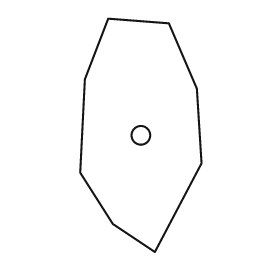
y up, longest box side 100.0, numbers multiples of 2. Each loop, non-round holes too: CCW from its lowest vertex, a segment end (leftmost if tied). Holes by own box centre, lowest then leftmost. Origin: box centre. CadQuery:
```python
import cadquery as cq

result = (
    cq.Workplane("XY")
    .moveTo(6.0, -50.0)
    .lineTo(26.0, -12.0)
    .lineTo(24.0, 20.0)
    .lineTo(12.0, 48.0)
    .lineTo(-14.0, 50.0)
    .lineTo(-24.0, 24.0)
    .lineTo(-26.0, -16.0)
    .lineTo(-12.0, -38.0)
    .close()
    .moveTo(0.0, 0.0)
    .circle(4.0)
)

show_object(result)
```